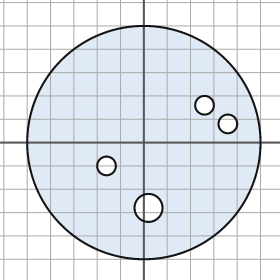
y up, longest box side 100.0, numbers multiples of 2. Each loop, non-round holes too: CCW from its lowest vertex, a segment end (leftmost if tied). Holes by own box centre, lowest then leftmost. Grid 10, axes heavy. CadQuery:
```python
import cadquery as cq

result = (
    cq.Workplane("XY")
    .moveTo(0.0, 0.0)
    .circle(50.0)
    .moveTo(2.0, -28.0)
    .circle(6.0)
    .moveTo(-16.0, -10.0)
    .circle(4.0)
    .moveTo(36.0, 8.0)
    .circle(4.0)
    .moveTo(26.0, 16.0)
    .circle(4.0)
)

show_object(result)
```